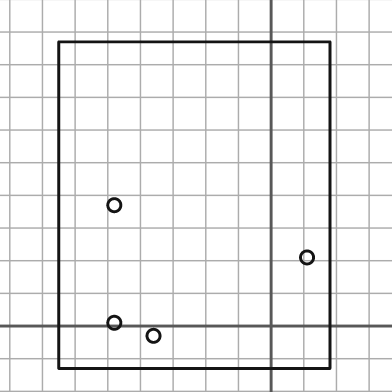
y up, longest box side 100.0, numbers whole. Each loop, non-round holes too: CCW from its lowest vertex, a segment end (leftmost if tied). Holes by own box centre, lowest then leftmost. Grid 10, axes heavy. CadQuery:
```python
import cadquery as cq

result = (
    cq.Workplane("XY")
    .moveTo(-65.0, -13.0)
    .lineTo(18.0, -13.0)
    .lineTo(18.0, 87.0)
    .lineTo(-65.0, 87.0)
    .close()
    .moveTo(-36.0, -3.0)
    .circle(2.0)
    .moveTo(-48.0, 1.0)
    .circle(2.0)
    .moveTo(11.0, 21.0)
    .circle(2.0)
    .moveTo(-48.0, 37.0)
    .circle(2.0)
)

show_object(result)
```